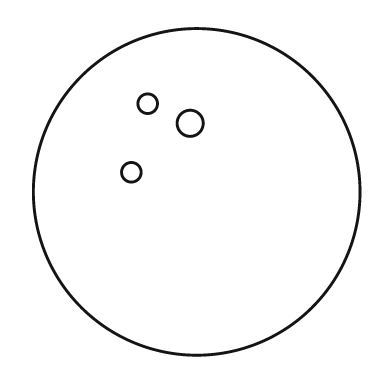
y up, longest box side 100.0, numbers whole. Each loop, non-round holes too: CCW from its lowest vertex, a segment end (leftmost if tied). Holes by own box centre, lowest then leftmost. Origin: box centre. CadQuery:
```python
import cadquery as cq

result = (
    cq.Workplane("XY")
    .moveTo(0.0, 0.0)
    .circle(50.0)
    .moveTo(-20.0, 6.0)
    .circle(3.0)
    .moveTo(-2.0, 21.0)
    .circle(4.0)
    .moveTo(-15.0, 27.0)
    .circle(3.0)
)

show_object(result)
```